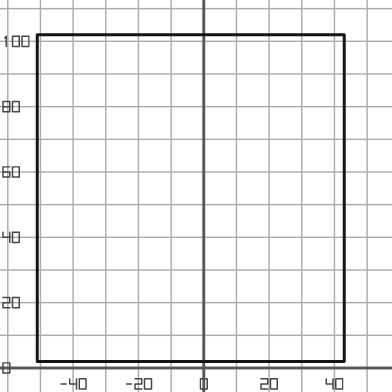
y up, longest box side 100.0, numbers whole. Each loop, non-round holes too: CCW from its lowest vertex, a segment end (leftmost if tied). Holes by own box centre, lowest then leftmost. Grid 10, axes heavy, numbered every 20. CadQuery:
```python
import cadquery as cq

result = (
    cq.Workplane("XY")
    .moveTo(-51.0, 2.0)
    .lineTo(43.0, 2.0)
    .lineTo(43.0, 102.0)
    .lineTo(-51.0, 102.0)
    .close()
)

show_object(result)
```